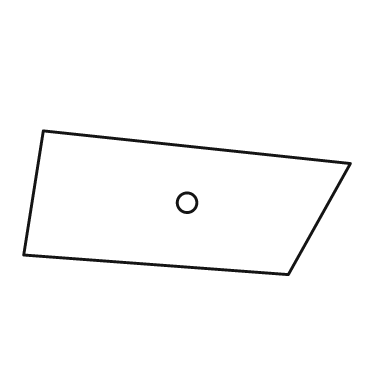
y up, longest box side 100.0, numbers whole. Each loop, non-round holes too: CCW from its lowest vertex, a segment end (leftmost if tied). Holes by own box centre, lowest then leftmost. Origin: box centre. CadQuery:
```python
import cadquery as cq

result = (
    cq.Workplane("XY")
    .moveTo(31.0, -22.0)
    .lineTo(50.0, 12.0)
    .lineTo(-44.0, 22.0)
    .lineTo(-50.0, -16.0)
    .close()
    .moveTo(0.0, 0.0)
    .circle(3.0)
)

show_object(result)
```